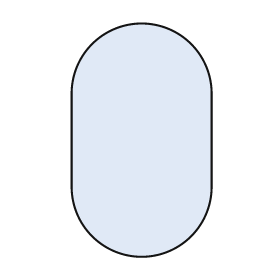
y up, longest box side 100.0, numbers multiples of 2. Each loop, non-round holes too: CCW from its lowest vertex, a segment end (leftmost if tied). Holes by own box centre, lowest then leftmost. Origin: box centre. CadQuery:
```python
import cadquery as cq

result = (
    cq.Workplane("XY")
    .moveTo(-30.0, -20.0)
    .threePointArc((0.0, -50.0), (30.0, -20.0))
    .lineTo(30.0, 20.0)
    .threePointArc((0.0, 50.0), (-30.0, 20.0))
    .close()
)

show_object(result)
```